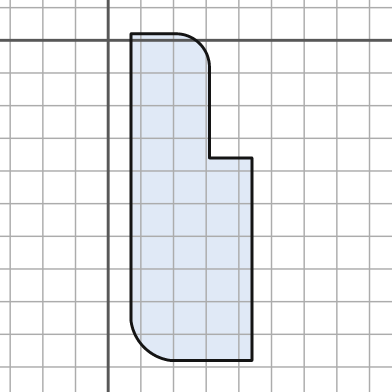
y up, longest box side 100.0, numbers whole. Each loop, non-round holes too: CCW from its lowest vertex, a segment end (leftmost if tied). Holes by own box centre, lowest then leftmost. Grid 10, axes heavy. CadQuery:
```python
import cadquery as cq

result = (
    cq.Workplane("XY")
    .moveTo(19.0, -98.0)
    .lineTo(44.0, -98.0)
    .lineTo(44.0, -36.0)
    .lineTo(31.0, -36.0)
    .lineTo(31.0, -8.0)
    .threePointArc((28.0, -1.0), (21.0, 2.0))
    .lineTo(7.0, 2.0)
    .lineTo(7.0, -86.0)
    .threePointArc((11.0, -94.0), (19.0, -98.0))
    .close()
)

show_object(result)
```